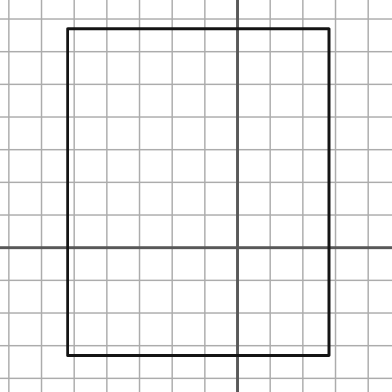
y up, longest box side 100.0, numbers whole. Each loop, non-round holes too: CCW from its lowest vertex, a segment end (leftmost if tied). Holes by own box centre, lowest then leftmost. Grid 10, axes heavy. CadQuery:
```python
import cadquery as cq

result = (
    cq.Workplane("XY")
    .moveTo(-52.0, -33.0)
    .lineTo(28.0, -33.0)
    .lineTo(28.0, 67.0)
    .lineTo(-52.0, 67.0)
    .close()
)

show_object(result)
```